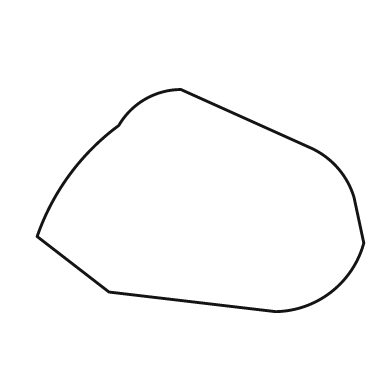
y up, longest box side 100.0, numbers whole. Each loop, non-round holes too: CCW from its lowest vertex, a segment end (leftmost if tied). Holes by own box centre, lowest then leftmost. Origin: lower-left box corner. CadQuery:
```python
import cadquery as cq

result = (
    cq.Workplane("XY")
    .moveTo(73.0, 0.0)
    .threePointArc((90.0, 6.0), (100.0, 21.0))
    .lineTo(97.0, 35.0)
    .threePointArc((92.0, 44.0), (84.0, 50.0))
    .lineTo(44.0, 68.0)
    .threePointArc((33.0, 65.0), (25.0, 57.0))
    .threePointArc((10.0, 42.0), (0.0, 23.0))
    .lineTo(22.0, 6.0)
    .close()
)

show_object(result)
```